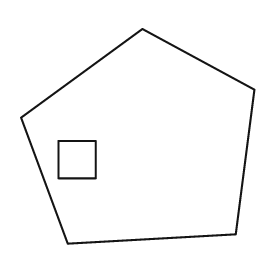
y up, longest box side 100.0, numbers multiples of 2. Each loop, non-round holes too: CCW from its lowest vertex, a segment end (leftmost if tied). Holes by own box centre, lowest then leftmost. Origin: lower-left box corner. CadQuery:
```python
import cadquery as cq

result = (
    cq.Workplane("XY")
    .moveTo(20.0, 0.0)
    .lineTo(92.0, 4.0)
    .lineTo(100.0, 66.0)
    .lineTo(52.0, 92.0)
    .lineTo(0.0, 54.0)
    .close()
    .moveTo(16.0, 28.0)
    .lineTo(32.0, 28.0)
    .lineTo(32.0, 44.0)
    .lineTo(16.0, 44.0)
    .close()
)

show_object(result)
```